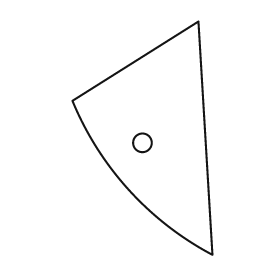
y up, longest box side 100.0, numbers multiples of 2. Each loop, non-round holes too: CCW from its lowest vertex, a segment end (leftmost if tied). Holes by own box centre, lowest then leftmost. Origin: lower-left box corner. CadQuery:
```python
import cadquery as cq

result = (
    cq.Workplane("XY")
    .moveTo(60.0, 0.0)
    .lineTo(54.0, 100.0)
    .lineTo(0.0, 66.0)
    .threePointArc((24.0, 28.0), (60.0, 0.0))
    .close()
    .moveTo(30.0, 48.0)
    .circle(4.0)
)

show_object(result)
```